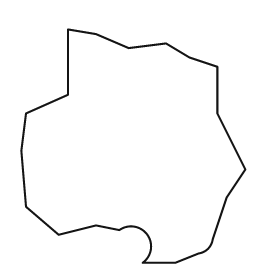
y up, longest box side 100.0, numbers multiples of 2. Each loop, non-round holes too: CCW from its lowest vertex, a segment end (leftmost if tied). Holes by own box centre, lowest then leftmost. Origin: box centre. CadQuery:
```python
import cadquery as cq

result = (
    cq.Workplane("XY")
    .moveTo(4.0, -50.0)
    .lineTo(18.0, -50.0)
    .lineTo(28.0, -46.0)
    .threePointArc((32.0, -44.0), (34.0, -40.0))
    .lineTo(40.0, -22.0)
    .lineTo(48.0, -10.0)
    .lineTo(36.0, 14.0)
    .lineTo(36.0, 34.0)
    .lineTo(24.0, 38.0)
    .lineTo(14.0, 44.0)
    .lineTo(-2.0, 42.0)
    .lineTo(-16.0, 48.0)
    .lineTo(-28.0, 50.0)
    .lineTo(-28.0, 22.0)
    .lineTo(-46.0, 14.0)
    .lineTo(-48.0, -2.0)
    .lineTo(-46.0, -26.0)
    .lineTo(-32.0, -38.0)
    .lineTo(-16.0, -34.0)
    .lineTo(-6.0, -36.0)
    .threePointArc((6.0, -38.0), (4.0, -50.0))
    .close()
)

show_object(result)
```